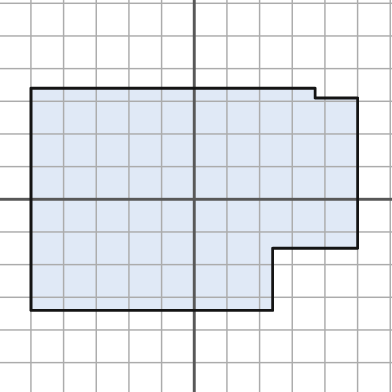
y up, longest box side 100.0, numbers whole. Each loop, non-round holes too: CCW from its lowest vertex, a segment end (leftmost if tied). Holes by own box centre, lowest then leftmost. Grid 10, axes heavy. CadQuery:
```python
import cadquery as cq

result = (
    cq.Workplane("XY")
    .moveTo(-50.0, -34.0)
    .lineTo(24.0, -34.0)
    .lineTo(24.0, -15.0)
    .lineTo(50.0, -15.0)
    .lineTo(50.0, 31.0)
    .lineTo(37.0, 31.0)
    .lineTo(37.0, 34.0)
    .lineTo(-50.0, 34.0)
    .close()
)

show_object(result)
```